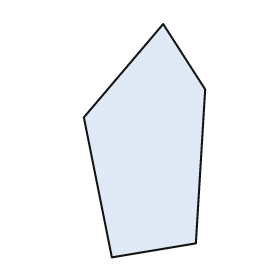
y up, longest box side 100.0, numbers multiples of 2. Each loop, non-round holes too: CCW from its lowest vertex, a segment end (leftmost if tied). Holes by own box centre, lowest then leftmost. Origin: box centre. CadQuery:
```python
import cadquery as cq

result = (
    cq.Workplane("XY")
    .moveTo(-14.0, -50.0)
    .lineTo(22.0, -44.0)
    .lineTo(26.0, 22.0)
    .lineTo(8.0, 50.0)
    .lineTo(-26.0, 10.0)
    .close()
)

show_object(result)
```